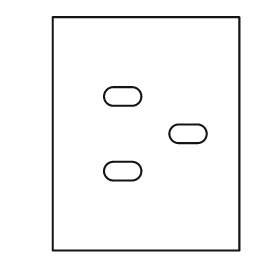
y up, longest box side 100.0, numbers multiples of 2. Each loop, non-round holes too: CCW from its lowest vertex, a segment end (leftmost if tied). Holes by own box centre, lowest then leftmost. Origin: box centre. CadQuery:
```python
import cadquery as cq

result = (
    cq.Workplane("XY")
    .moveTo(-40.0, -50.0)
    .lineTo(40.0, -50.0)
    .lineTo(40.0, 50.0)
    .lineTo(-40.0, 50.0)
    .close()
    .moveTo(-14.0, -20.0)
    .lineTo(-6.0, -20.0)
    .threePointArc((-2.0, -16.0), (-6.0, -12.0))
    .lineTo(-14.0, -12.0)
    .threePointArc((-18.0, -16.0), (-14.0, -20.0))
    .close()
    .moveTo(14.0, -4.0)
    .lineTo(22.0, -4.0)
    .threePointArc((26.0, 0.0), (22.0, 4.0))
    .lineTo(14.0, 4.0)
    .threePointArc((10.0, 0.0), (14.0, -4.0))
    .close()
    .moveTo(-14.0, 12.0)
    .lineTo(-6.0, 12.0)
    .threePointArc((-2.0, 16.0), (-6.0, 20.0))
    .lineTo(-14.0, 20.0)
    .threePointArc((-18.0, 16.0), (-14.0, 12.0))
    .close()
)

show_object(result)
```